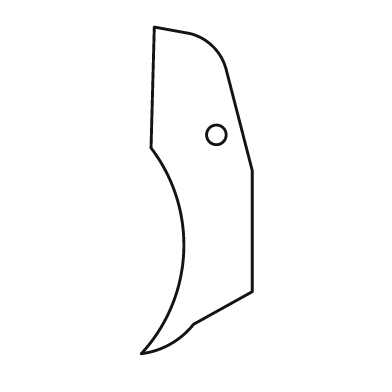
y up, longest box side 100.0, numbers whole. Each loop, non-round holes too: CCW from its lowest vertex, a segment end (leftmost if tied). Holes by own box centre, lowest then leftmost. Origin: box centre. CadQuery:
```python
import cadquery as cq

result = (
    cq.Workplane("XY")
    .moveTo(-17.0, -50.0)
    .threePointArc((-8.0, -47.0), (-1.0, -41.0))
    .lineTo(17.0, -31.0)
    .lineTo(17.0, 6.0)
    .lineTo(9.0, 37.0)
    .threePointArc((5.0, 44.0), (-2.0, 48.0))
    .lineTo(-13.0, 50.0)
    .lineTo(-14.0, 13.0)
    .threePointArc((-4.0, -19.0), (-17.0, -50.0))
    .close()
    .moveTo(6.0, 17.0)
    .circle(3.0)
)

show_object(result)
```